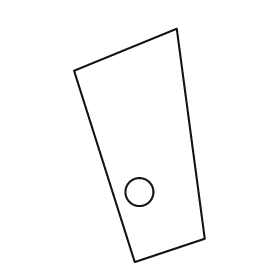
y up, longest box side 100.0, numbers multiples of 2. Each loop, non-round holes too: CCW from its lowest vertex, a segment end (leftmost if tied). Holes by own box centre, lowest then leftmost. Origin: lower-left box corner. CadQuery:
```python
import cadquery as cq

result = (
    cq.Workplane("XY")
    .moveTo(26.0, 0.0)
    .lineTo(56.0, 10.0)
    .lineTo(44.0, 100.0)
    .lineTo(0.0, 82.0)
    .close()
    .moveTo(28.0, 30.0)
    .circle(6.0)
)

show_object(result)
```